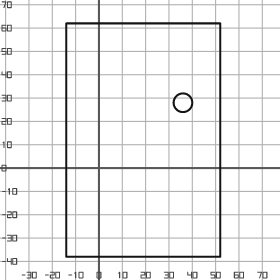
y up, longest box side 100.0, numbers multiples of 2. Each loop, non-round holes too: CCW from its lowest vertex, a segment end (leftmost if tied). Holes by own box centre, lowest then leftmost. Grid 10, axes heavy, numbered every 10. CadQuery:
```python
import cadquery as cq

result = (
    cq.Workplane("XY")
    .moveTo(-14.0, -38.0)
    .lineTo(52.0, -38.0)
    .lineTo(52.0, 62.0)
    .lineTo(-14.0, 62.0)
    .close()
    .moveTo(36.0, 28.0)
    .circle(4.0)
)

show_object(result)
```